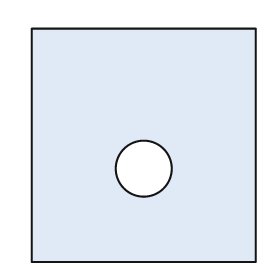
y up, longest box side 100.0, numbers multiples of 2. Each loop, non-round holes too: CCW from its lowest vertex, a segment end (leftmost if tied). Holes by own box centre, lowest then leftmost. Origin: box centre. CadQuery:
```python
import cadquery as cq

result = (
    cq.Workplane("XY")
    .moveTo(-48.0, -50.0)
    .lineTo(48.0, -50.0)
    .lineTo(48.0, 50.0)
    .lineTo(-48.0, 50.0)
    .close()
    .moveTo(0.0, -10.0)
    .circle(12.0)
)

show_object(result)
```